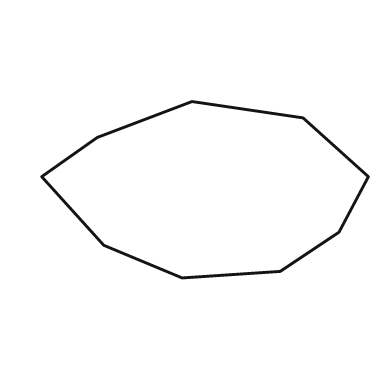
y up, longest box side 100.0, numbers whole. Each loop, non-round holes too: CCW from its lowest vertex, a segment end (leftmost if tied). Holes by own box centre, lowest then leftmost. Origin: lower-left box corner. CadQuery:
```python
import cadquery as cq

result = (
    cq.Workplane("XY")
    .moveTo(43.0, 0.0)
    .lineTo(73.0, 2.0)
    .lineTo(91.0, 14.0)
    .lineTo(100.0, 31.0)
    .lineTo(80.0, 49.0)
    .lineTo(46.0, 54.0)
    .lineTo(17.0, 43.0)
    .lineTo(0.0, 31.0)
    .lineTo(19.0, 10.0)
    .close()
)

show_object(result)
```